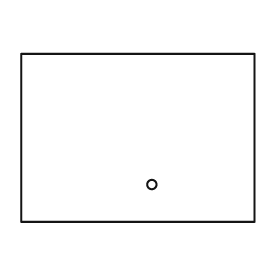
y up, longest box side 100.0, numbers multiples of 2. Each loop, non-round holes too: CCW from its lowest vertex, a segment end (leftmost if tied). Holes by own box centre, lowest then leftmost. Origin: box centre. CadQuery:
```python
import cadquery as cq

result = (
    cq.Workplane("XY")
    .moveTo(-50.0, -36.0)
    .lineTo(50.0, -36.0)
    .lineTo(50.0, 36.0)
    .lineTo(-50.0, 36.0)
    .close()
    .moveTo(6.0, -20.0)
    .circle(2.0)
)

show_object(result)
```